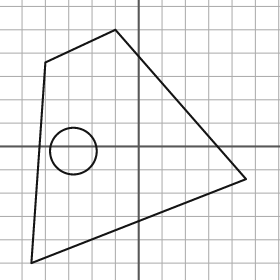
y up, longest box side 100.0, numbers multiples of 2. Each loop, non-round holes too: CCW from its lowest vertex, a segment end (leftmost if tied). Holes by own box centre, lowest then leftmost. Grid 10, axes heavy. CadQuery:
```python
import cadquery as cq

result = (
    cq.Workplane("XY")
    .moveTo(-46.0, -50.0)
    .lineTo(46.0, -14.0)
    .lineTo(-10.0, 50.0)
    .lineTo(-40.0, 36.0)
    .close()
    .moveTo(-28.0, -2.0)
    .circle(10.0)
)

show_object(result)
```